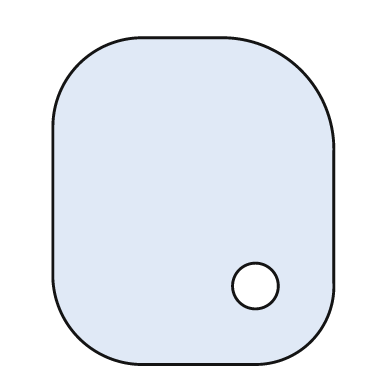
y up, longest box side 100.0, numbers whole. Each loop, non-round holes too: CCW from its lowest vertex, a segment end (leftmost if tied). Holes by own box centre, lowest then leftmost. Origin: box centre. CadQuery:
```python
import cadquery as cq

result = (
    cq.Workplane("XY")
    .moveTo(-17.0, -50.0)
    .lineTo(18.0, -50.0)
    .threePointArc((36.0, -43.0), (43.0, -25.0))
    .lineTo(43.0, 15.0)
    .threePointArc((33.0, 40.0), (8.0, 50.0))
    .lineTo(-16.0, 50.0)
    .threePointArc((-35.0, 42.0), (-43.0, 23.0))
    .lineTo(-43.0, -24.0)
    .threePointArc((-35.0, -42.0), (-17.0, -50.0))
    .close()
    .moveTo(19.0, -26.0)
    .circle(7.0)
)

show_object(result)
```